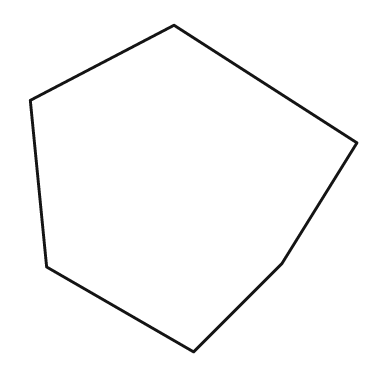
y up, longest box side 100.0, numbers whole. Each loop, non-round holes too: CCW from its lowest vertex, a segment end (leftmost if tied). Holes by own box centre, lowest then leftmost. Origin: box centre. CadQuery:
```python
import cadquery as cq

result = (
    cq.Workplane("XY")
    .moveTo(0.0, -50.0)
    .lineTo(27.0, -23.0)
    .lineTo(50.0, 14.0)
    .lineTo(-6.0, 50.0)
    .lineTo(-50.0, 27.0)
    .lineTo(-45.0, -24.0)
    .close()
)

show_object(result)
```